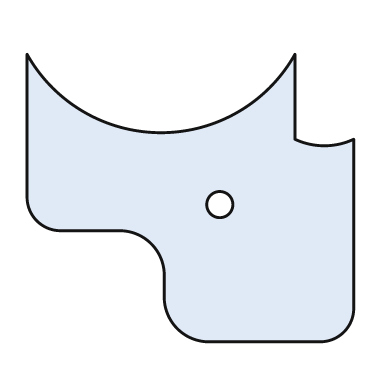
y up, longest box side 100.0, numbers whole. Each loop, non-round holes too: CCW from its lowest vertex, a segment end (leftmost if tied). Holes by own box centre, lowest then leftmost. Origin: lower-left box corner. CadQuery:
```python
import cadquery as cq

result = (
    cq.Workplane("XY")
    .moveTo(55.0, 0.0)
    .lineTo(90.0, 0.0)
    .threePointArc((97.0, 3.0), (100.0, 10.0))
    .lineTo(100.0, 62.0)
    .threePointArc((91.0, 60.0), (82.0, 62.0))
    .lineTo(82.0, 88.0)
    .threePointArc((41.0, 64.0), (0.0, 88.0))
    .lineTo(0.0, 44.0)
    .threePointArc((3.0, 37.0), (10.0, 34.0))
    .lineTo(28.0, 34.0)
    .threePointArc((38.0, 30.0), (42.0, 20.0))
    .lineTo(42.0, 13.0)
    .threePointArc((46.0, 4.0), (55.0, 0.0))
    .close()
    .moveTo(59.0, 42.0)
    .circle(4.0)
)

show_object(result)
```